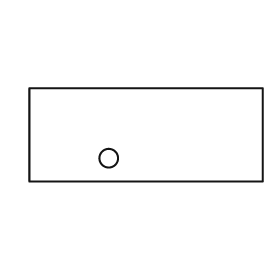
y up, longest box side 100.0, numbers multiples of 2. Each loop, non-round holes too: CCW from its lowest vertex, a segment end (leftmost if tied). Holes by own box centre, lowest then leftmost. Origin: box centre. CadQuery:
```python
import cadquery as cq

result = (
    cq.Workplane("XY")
    .moveTo(-50.0, -20.0)
    .lineTo(50.0, -20.0)
    .lineTo(50.0, 20.0)
    .lineTo(-50.0, 20.0)
    .close()
    .moveTo(-16.0, -10.0)
    .circle(4.0)
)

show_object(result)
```